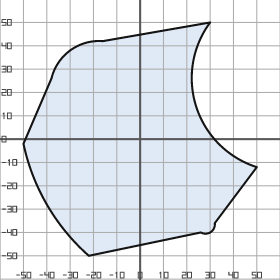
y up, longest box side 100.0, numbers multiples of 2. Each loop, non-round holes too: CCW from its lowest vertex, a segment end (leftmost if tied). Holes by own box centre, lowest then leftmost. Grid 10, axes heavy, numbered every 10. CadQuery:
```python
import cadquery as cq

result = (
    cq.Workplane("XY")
    .moveTo(-22.0, -50.0)
    .lineTo(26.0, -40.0)
    .threePointArc((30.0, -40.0), (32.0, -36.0))
    .lineTo(50.0, -12.0)
    .threePointArc((24.0, 14.0), (30.0, 50.0))
    .lineTo(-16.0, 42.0)
    .threePointArc((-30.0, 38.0), (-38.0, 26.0))
    .lineTo(-50.0, -2.0)
    .threePointArc((-40.0, -28.0), (-22.0, -50.0))
    .close()
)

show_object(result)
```